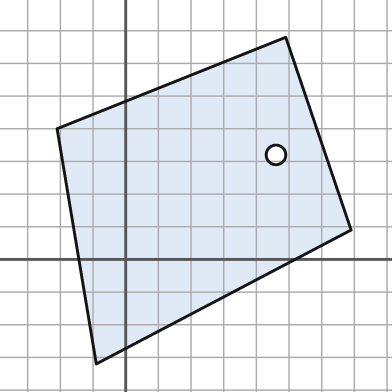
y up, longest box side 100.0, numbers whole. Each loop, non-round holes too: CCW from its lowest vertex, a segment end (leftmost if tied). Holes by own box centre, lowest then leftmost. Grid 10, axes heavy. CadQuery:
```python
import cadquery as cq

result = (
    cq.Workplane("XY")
    .moveTo(-9.0, -32.0)
    .lineTo(69.0, 9.0)
    .lineTo(49.0, 68.0)
    .lineTo(-21.0, 40.0)
    .close()
    .moveTo(46.0, 32.0)
    .circle(3.0)
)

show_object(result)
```